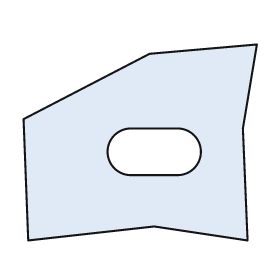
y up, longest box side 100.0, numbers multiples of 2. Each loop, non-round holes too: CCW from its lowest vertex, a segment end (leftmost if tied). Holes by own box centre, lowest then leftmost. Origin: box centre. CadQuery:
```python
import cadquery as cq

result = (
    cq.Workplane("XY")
    .moveTo(-48.0, -42.0)
    .lineTo(6.0, -36.0)
    .lineTo(46.0, -42.0)
    .lineTo(44.0, 6.0)
    .lineTo(50.0, 42.0)
    .lineTo(4.0, 38.0)
    .lineTo(-50.0, 10.0)
    .close()
    .moveTo(-4.0, -14.0)
    .lineTo(16.0, -14.0)
    .threePointArc((26.0, -4.0), (16.0, 6.0))
    .lineTo(-4.0, 6.0)
    .threePointArc((-14.0, -4.0), (-4.0, -14.0))
    .close()
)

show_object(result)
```